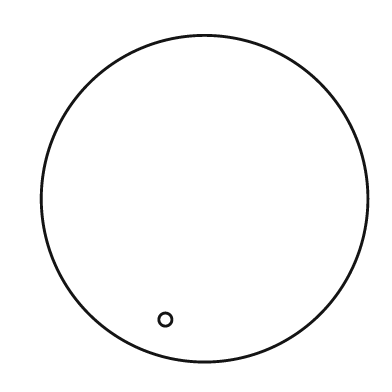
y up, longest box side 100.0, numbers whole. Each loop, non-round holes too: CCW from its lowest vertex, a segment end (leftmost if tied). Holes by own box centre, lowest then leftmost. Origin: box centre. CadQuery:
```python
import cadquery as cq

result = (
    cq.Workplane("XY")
    .moveTo(0.0, 0.0)
    .circle(50.0)
    .moveTo(-12.0, -37.0)
    .circle(2.0)
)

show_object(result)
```